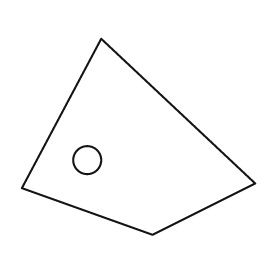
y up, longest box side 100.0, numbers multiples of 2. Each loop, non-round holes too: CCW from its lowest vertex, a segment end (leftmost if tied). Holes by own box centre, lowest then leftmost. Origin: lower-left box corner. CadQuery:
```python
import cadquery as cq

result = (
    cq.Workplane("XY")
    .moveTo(56.0, 0.0)
    .lineTo(100.0, 22.0)
    .lineTo(34.0, 84.0)
    .lineTo(0.0, 20.0)
    .close()
    .moveTo(28.0, 32.0)
    .circle(6.0)
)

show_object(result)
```